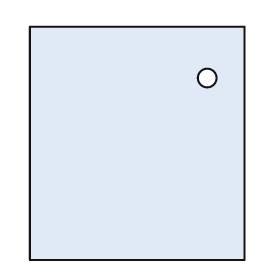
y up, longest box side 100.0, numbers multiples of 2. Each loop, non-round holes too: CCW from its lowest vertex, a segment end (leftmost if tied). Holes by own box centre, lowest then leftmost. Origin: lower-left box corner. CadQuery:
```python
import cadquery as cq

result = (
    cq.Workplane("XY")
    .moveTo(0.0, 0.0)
    .lineTo(92.0, 0.0)
    .lineTo(92.0, 100.0)
    .lineTo(0.0, 100.0)
    .close()
    .moveTo(76.0, 78.0)
    .circle(4.0)
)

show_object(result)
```